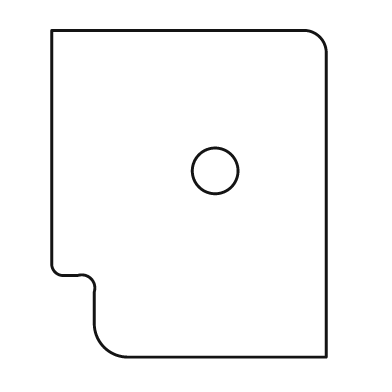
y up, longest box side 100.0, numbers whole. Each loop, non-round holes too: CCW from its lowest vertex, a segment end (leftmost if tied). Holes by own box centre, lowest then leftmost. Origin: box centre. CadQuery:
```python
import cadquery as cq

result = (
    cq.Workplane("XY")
    .moveTo(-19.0, -50.0)
    .lineTo(42.0, -50.0)
    .lineTo(42.0, 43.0)
    .threePointArc((40.0, 48.0), (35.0, 50.0))
    .lineTo(-42.0, 50.0)
    .lineTo(-42.0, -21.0)
    .threePointArc((-41.0, -24.0), (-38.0, -25.0))
    .lineTo(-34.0, -25.0)
    .threePointArc((-30.0, -26.0), (-29.0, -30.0))
    .lineTo(-29.0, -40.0)
    .threePointArc((-26.0, -47.0), (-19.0, -50.0))
    .close()
    .moveTo(8.0, 7.0)
    .circle(7.0)
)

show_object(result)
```